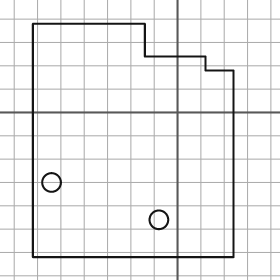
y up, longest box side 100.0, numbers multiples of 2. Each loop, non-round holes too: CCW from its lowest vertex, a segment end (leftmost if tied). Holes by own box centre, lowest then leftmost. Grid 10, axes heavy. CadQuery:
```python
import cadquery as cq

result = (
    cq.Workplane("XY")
    .moveTo(-62.0, -62.0)
    .lineTo(24.0, -62.0)
    .lineTo(24.0, 18.0)
    .lineTo(12.0, 18.0)
    .lineTo(12.0, 24.0)
    .lineTo(-14.0, 24.0)
    .lineTo(-14.0, 38.0)
    .lineTo(-62.0, 38.0)
    .close()
    .moveTo(-8.0, -46.0)
    .circle(4.0)
    .moveTo(-54.0, -30.0)
    .circle(4.0)
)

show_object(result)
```